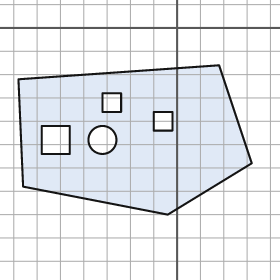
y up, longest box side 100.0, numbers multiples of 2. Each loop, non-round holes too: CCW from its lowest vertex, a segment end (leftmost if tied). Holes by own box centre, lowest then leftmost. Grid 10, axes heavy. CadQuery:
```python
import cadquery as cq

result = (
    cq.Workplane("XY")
    .moveTo(-4.0, -80.0)
    .lineTo(32.0, -58.0)
    .lineTo(18.0, -16.0)
    .lineTo(-68.0, -22.0)
    .lineTo(-66.0, -68.0)
    .close()
    .moveTo(-58.0, -54.0)
    .lineTo(-46.0, -54.0)
    .lineTo(-46.0, -42.0)
    .lineTo(-58.0, -42.0)
    .close()
    .moveTo(-32.0, -48.0)
    .circle(6.0)
    .moveTo(-10.0, -44.0)
    .lineTo(-2.0, -44.0)
    .lineTo(-2.0, -36.0)
    .lineTo(-10.0, -36.0)
    .close()
    .moveTo(-32.0, -36.0)
    .lineTo(-24.0, -36.0)
    .lineTo(-24.0, -28.0)
    .lineTo(-32.0, -28.0)
    .close()
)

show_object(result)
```